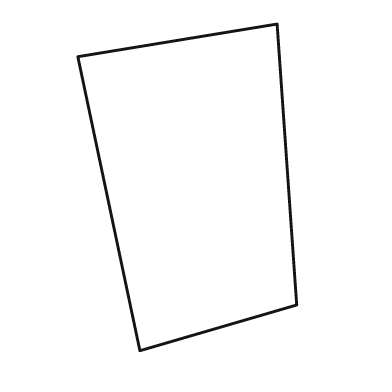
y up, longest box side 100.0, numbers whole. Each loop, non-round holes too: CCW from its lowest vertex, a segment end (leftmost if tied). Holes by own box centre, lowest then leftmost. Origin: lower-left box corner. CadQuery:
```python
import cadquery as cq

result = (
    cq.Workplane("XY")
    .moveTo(19.0, 0.0)
    .lineTo(67.0, 14.0)
    .lineTo(61.0, 100.0)
    .lineTo(0.0, 90.0)
    .close()
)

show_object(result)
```